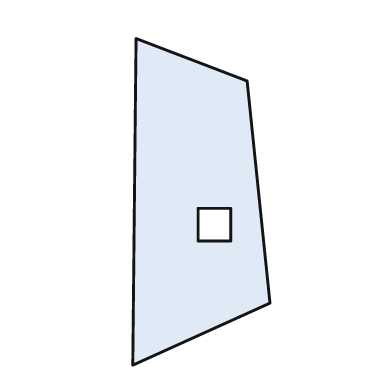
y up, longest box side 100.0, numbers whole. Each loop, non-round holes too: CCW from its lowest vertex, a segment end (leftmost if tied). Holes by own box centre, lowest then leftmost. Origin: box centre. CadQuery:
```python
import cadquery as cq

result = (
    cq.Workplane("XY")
    .moveTo(-21.0, -50.0)
    .lineTo(21.0, -31.0)
    .lineTo(14.0, 37.0)
    .lineTo(-20.0, 50.0)
    .close()
    .moveTo(-1.0, -12.0)
    .lineTo(9.0, -12.0)
    .lineTo(9.0, -2.0)
    .lineTo(-1.0, -2.0)
    .close()
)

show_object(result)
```